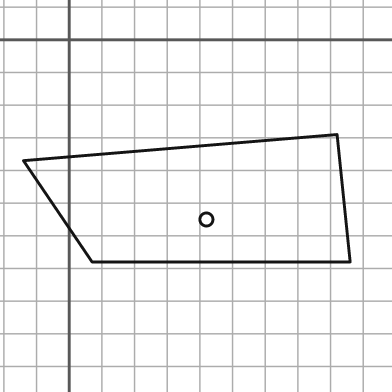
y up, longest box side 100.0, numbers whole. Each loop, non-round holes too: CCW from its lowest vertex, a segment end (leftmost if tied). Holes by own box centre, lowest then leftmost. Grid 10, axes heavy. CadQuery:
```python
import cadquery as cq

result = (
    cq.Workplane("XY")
    .moveTo(7.0, -68.0)
    .lineTo(86.0, -68.0)
    .lineTo(82.0, -29.0)
    .lineTo(-14.0, -37.0)
    .close()
    .moveTo(42.0, -55.0)
    .circle(2.0)
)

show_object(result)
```